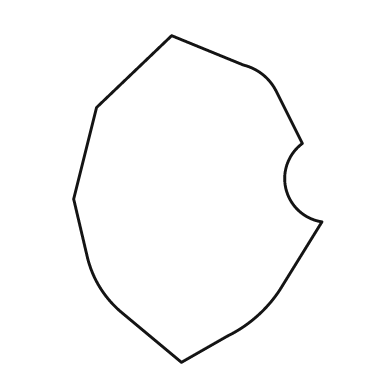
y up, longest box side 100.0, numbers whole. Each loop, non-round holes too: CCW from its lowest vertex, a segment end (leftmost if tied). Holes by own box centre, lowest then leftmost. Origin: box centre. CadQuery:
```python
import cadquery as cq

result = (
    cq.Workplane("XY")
    .moveTo(-5.0, -50.0)
    .lineTo(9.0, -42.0)
    .threePointArc((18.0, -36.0), (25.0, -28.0))
    .lineTo(38.0, -7.0)
    .threePointArc((27.0, 3.0), (32.0, 17.0))
    .lineTo(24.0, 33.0)
    .threePointArc((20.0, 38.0), (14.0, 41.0))
    .lineTo(-8.0, 50.0)
    .lineTo(-31.0, 28.0)
    .lineTo(-38.0, 0.0)
    .lineTo(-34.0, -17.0)
    .threePointArc((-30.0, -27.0), (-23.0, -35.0))
    .close()
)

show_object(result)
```